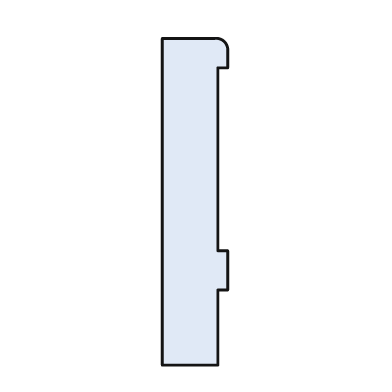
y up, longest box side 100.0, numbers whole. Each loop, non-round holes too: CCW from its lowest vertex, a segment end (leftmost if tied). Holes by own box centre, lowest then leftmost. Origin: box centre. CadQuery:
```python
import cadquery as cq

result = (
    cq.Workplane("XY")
    .moveTo(-10.0, -50.0)
    .lineTo(7.0, -50.0)
    .lineTo(7.0, -27.0)
    .lineTo(10.0, -27.0)
    .lineTo(10.0, -15.0)
    .lineTo(7.0, -15.0)
    .lineTo(7.0, 41.0)
    .lineTo(10.0, 41.0)
    .lineTo(10.0, 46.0)
    .threePointArc((9.0, 49.0), (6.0, 50.0))
    .lineTo(-10.0, 50.0)
    .close()
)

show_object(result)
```